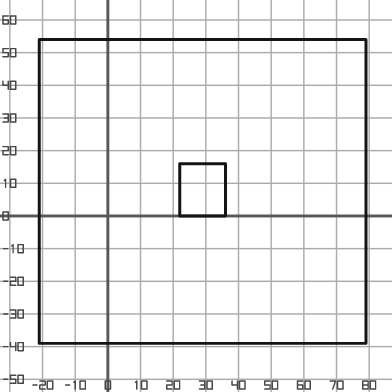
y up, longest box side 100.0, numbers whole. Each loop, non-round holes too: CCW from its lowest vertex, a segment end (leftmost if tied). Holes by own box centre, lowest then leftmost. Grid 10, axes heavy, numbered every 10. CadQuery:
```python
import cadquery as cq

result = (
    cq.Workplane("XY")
    .moveTo(-21.0, -39.0)
    .lineTo(79.0, -39.0)
    .lineTo(79.0, 54.0)
    .lineTo(-21.0, 54.0)
    .close()
    .moveTo(22.0, 0.0)
    .lineTo(36.0, 0.0)
    .lineTo(36.0, 16.0)
    .lineTo(22.0, 16.0)
    .close()
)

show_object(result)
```